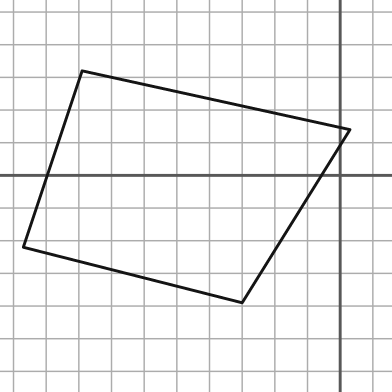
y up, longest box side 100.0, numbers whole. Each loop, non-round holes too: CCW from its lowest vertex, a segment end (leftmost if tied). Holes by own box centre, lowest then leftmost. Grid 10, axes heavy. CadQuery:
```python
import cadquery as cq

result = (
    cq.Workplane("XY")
    .moveTo(-30.0, -39.0)
    .lineTo(3.0, 14.0)
    .lineTo(-79.0, 32.0)
    .lineTo(-97.0, -22.0)
    .close()
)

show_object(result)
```